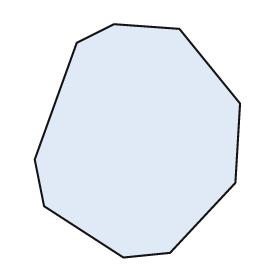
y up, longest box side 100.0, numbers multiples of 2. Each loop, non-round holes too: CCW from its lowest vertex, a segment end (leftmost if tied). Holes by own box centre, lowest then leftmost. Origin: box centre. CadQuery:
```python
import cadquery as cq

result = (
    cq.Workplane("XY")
    .moveTo(-6.0, -50.0)
    .lineTo(14.0, -48.0)
    .lineTo(42.0, -18.0)
    .lineTo(44.0, 16.0)
    .lineTo(18.0, 48.0)
    .lineTo(-10.0, 50.0)
    .lineTo(-26.0, 42.0)
    .lineTo(-44.0, -8.0)
    .lineTo(-40.0, -28.0)
    .close()
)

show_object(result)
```